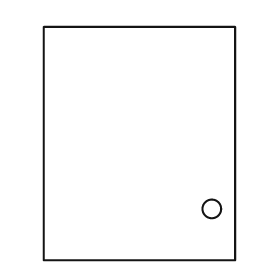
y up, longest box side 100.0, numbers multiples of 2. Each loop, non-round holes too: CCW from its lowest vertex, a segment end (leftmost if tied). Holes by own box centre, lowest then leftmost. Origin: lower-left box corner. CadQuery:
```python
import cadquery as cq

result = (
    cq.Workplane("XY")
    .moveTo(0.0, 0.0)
    .lineTo(82.0, 0.0)
    .lineTo(82.0, 100.0)
    .lineTo(0.0, 100.0)
    .close()
    .moveTo(72.0, 22.0)
    .circle(4.0)
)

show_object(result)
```